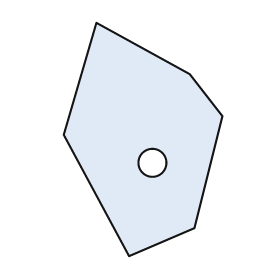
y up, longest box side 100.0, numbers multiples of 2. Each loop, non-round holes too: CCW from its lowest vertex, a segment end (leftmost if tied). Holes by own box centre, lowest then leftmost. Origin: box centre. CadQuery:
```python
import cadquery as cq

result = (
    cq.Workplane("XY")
    .moveTo(-6.0, -50.0)
    .lineTo(22.0, -38.0)
    .lineTo(34.0, 10.0)
    .lineTo(20.0, 28.0)
    .lineTo(-20.0, 50.0)
    .lineTo(-34.0, 2.0)
    .close()
    .moveTo(4.0, -10.0)
    .circle(6.0)
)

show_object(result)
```